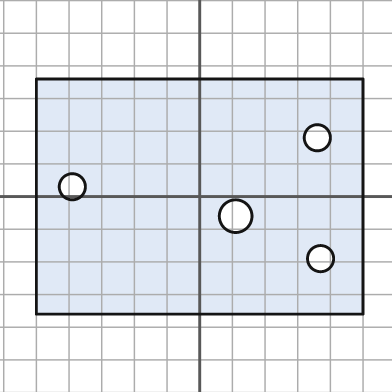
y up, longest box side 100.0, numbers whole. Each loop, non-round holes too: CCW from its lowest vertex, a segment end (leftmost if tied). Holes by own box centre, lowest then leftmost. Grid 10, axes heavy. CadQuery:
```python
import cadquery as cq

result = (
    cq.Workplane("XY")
    .moveTo(-50.0, -36.0)
    .lineTo(50.0, -36.0)
    .lineTo(50.0, 36.0)
    .lineTo(-50.0, 36.0)
    .close()
    .moveTo(37.0, -19.0)
    .circle(4.0)
    .moveTo(11.0, -6.0)
    .circle(5.0)
    .moveTo(-39.0, 3.0)
    .circle(4.0)
    .moveTo(36.0, 18.0)
    .circle(4.0)
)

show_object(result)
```